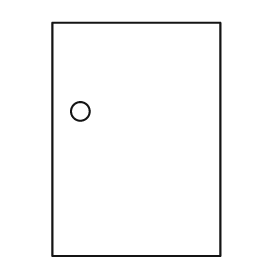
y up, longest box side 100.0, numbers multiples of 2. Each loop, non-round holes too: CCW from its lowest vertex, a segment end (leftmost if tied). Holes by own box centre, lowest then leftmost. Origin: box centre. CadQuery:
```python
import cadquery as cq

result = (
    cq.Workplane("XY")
    .moveTo(-36.0, -50.0)
    .lineTo(36.0, -50.0)
    .lineTo(36.0, 50.0)
    .lineTo(-36.0, 50.0)
    .close()
    .moveTo(-24.0, 12.0)
    .circle(4.0)
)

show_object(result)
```